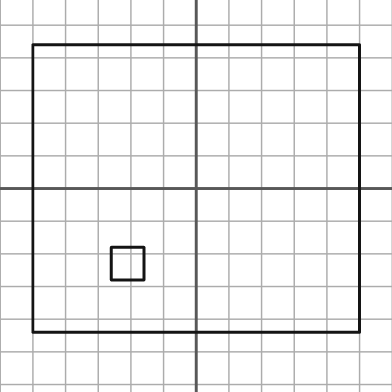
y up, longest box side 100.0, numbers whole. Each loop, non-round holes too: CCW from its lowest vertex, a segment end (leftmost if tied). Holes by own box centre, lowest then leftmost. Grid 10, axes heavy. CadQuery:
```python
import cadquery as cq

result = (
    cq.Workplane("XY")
    .moveTo(-50.0, -44.0)
    .lineTo(50.0, -44.0)
    .lineTo(50.0, 44.0)
    .lineTo(-50.0, 44.0)
    .close()
    .moveTo(-26.0, -28.0)
    .lineTo(-16.0, -28.0)
    .lineTo(-16.0, -18.0)
    .lineTo(-26.0, -18.0)
    .close()
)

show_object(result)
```